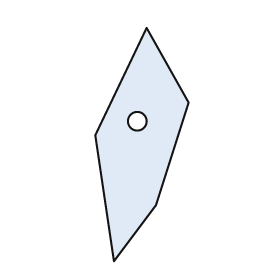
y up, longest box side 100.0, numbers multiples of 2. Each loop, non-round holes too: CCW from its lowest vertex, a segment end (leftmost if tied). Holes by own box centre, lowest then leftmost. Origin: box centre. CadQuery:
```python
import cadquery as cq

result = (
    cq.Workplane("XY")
    .moveTo(-12.0, -50.0)
    .lineTo(6.0, -26.0)
    .lineTo(20.0, 18.0)
    .lineTo(2.0, 50.0)
    .lineTo(-20.0, 4.0)
    .close()
    .moveTo(-2.0, 10.0)
    .circle(4.0)
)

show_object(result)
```